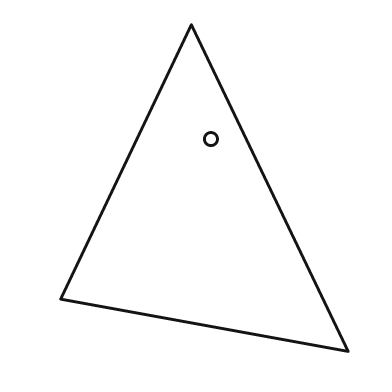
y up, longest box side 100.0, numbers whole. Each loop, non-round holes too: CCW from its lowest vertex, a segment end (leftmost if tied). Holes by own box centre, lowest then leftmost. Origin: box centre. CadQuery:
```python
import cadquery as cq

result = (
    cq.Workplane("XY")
    .moveTo(44.0, -50.0)
    .lineTo(-4.0, 50.0)
    .lineTo(-44.0, -34.0)
    .close()
    .moveTo(2.0, 15.0)
    .circle(2.0)
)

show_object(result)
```